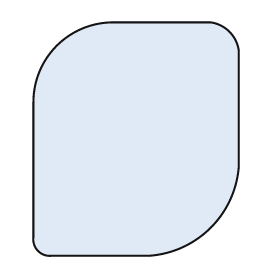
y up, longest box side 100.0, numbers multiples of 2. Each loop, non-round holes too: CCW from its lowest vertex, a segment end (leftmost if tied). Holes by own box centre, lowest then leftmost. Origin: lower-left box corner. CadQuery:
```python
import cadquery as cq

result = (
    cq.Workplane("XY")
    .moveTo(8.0, 0.0)
    .lineTo(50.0, 0.0)
    .threePointArc((76.0, 12.0), (88.0, 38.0))
    .lineTo(88.0, 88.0)
    .threePointArc((84.0, 96.0), (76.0, 100.0))
    .lineTo(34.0, 100.0)
    .threePointArc((10.0, 90.0), (0.0, 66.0))
    .lineTo(0.0, 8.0)
    .threePointArc((2.0, 2.0), (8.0, 0.0))
    .close()
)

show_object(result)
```